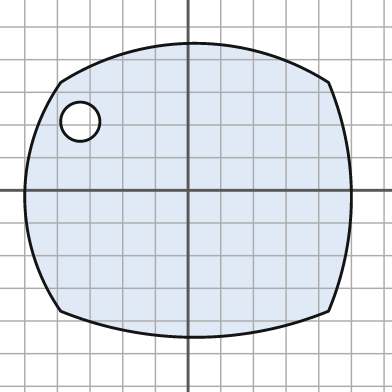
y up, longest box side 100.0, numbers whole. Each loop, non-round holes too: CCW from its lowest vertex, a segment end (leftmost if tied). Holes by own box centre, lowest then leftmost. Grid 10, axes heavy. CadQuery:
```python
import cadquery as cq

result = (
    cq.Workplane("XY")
    .moveTo(-39.0, -37.0)
    .threePointArc((2.0, -45.0), (43.0, -37.0))
    .threePointArc((50.0, -2.0), (43.0, 33.0))
    .threePointArc((2.0, 45.0), (-39.0, 33.0))
    .threePointArc((-50.0, -2.0), (-39.0, -37.0))
    .close()
    .moveTo(-33.0, 21.0)
    .circle(6.0)
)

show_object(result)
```